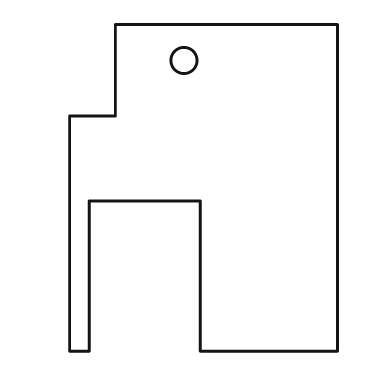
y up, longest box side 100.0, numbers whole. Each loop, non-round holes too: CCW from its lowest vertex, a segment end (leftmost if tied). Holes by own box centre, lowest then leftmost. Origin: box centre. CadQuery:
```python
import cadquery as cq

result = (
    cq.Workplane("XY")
    .moveTo(-41.0, -50.0)
    .lineTo(-35.0, -50.0)
    .lineTo(-35.0, -4.0)
    .lineTo(-1.0, -4.0)
    .lineTo(-1.0, -50.0)
    .lineTo(41.0, -50.0)
    .lineTo(41.0, 50.0)
    .lineTo(-27.0, 50.0)
    .lineTo(-27.0, 22.0)
    .lineTo(-41.0, 22.0)
    .close()
    .moveTo(-6.0, 39.0)
    .circle(4.0)
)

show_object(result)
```